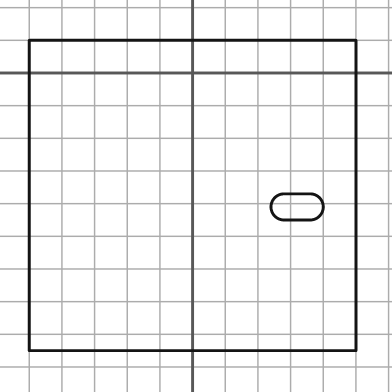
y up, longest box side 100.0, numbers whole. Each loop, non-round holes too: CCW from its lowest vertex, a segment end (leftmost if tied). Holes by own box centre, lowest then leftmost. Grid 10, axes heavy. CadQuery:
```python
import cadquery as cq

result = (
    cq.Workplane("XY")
    .moveTo(-50.0, -85.0)
    .lineTo(50.0, -85.0)
    .lineTo(50.0, 10.0)
    .lineTo(-50.0, 10.0)
    .close()
    .moveTo(28.0, -45.0)
    .lineTo(36.0, -45.0)
    .threePointArc((40.0, -41.0), (36.0, -37.0))
    .lineTo(28.0, -37.0)
    .threePointArc((24.0, -41.0), (28.0, -45.0))
    .close()
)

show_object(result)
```